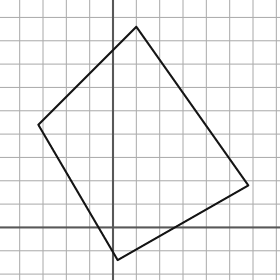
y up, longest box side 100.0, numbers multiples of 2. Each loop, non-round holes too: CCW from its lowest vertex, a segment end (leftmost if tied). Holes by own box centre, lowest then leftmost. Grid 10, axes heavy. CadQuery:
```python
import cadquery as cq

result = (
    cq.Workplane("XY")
    .moveTo(2.0, -14.0)
    .lineTo(58.0, 18.0)
    .lineTo(10.0, 86.0)
    .lineTo(-32.0, 44.0)
    .close()
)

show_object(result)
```